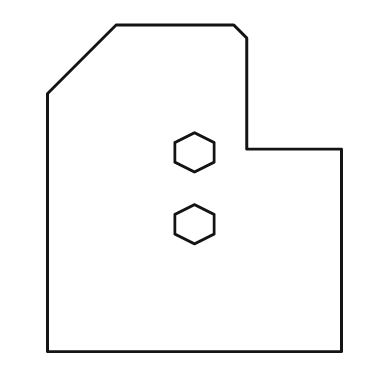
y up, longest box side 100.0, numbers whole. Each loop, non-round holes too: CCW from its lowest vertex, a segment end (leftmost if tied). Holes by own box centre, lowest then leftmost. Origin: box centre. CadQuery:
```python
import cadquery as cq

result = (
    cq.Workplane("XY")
    .moveTo(-45.0, -50.0)
    .lineTo(45.0, -50.0)
    .lineTo(45.0, 12.0)
    .lineTo(16.0, 12.0)
    .lineTo(16.0, 46.0)
    .lineTo(12.0, 50.0)
    .lineTo(-24.0, 50.0)
    .lineTo(-45.0, 29.0)
    .close()
    .moveTo(0.0, -17.0)
    .lineTo(6.0, -14.0)
    .lineTo(6.0, -8.0)
    .lineTo(0.0, -5.0)
    .lineTo(-6.0, -8.0)
    .lineTo(-6.0, -14.0)
    .close()
    .moveTo(0.0, 5.0)
    .lineTo(6.0, 8.0)
    .lineTo(6.0, 14.0)
    .lineTo(0.0, 17.0)
    .lineTo(-6.0, 14.0)
    .lineTo(-6.0, 8.0)
    .close()
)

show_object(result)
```